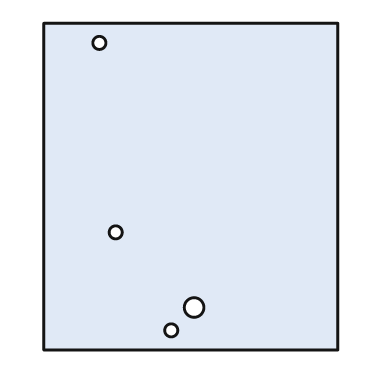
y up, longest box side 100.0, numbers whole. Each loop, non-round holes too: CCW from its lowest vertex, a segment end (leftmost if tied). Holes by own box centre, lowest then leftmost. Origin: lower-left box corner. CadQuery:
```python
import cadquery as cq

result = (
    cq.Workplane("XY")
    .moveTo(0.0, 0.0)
    .lineTo(90.0, 0.0)
    .lineTo(90.0, 100.0)
    .lineTo(0.0, 100.0)
    .close()
    .moveTo(39.0, 6.0)
    .circle(2.0)
    .moveTo(46.0, 13.0)
    .circle(3.0)
    .moveTo(22.0, 36.0)
    .circle(2.0)
    .moveTo(17.0, 94.0)
    .circle(2.0)
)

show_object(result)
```